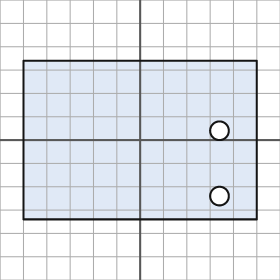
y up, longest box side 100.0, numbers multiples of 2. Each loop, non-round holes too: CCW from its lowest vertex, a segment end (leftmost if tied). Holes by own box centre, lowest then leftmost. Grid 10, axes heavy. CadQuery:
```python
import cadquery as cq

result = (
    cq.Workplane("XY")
    .moveTo(-50.0, -34.0)
    .lineTo(50.0, -34.0)
    .lineTo(50.0, 34.0)
    .lineTo(-50.0, 34.0)
    .close()
    .moveTo(34.0, -24.0)
    .circle(4.0)
    .moveTo(34.0, 4.0)
    .circle(4.0)
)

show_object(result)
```